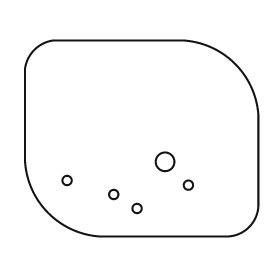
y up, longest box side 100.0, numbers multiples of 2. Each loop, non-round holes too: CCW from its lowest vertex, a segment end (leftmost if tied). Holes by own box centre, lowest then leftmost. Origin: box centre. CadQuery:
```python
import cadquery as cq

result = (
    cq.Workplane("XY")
    .moveTo(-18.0, -42.0)
    .lineTo(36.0, -42.0)
    .threePointArc((46.0, -38.0), (50.0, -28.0))
    .lineTo(50.0, 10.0)
    .threePointArc((40.0, 32.0), (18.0, 42.0))
    .lineTo(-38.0, 42.0)
    .threePointArc((-46.0, 38.0), (-50.0, 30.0))
    .lineTo(-50.0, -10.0)
    .threePointArc((-40.0, -32.0), (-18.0, -42.0))
    .close()
    .moveTo(-2.0, -30.0)
    .circle(2.0)
    .moveTo(-12.0, -24.0)
    .circle(2.0)
    .moveTo(20.0, -20.0)
    .circle(2.0)
    .moveTo(-32.0, -18.0)
    .circle(2.0)
    .moveTo(10.0, -10.0)
    .circle(4.0)
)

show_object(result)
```